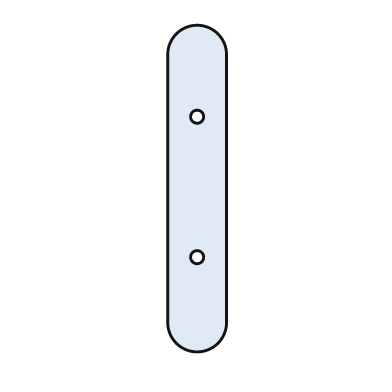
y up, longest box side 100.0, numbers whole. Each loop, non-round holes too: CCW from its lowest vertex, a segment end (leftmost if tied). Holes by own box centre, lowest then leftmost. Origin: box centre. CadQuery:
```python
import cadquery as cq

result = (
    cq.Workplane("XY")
    .moveTo(-9.0, -41.0)
    .threePointArc((0.0, -50.0), (9.0, -41.0))
    .lineTo(9.0, 41.0)
    .threePointArc((0.0, 50.0), (-9.0, 41.0))
    .close()
    .moveTo(0.0, -21.0)
    .circle(2.0)
    .moveTo(0.0, 22.0)
    .circle(2.0)
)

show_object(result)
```